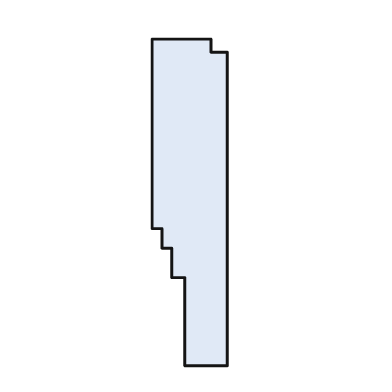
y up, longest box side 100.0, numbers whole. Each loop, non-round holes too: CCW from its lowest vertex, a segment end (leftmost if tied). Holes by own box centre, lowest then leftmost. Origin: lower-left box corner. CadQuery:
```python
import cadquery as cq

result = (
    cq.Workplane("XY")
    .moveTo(10.0, 0.0)
    .lineTo(23.0, 0.0)
    .lineTo(23.0, 96.0)
    .lineTo(18.0, 96.0)
    .lineTo(18.0, 100.0)
    .lineTo(0.0, 100.0)
    .lineTo(0.0, 42.0)
    .lineTo(3.0, 42.0)
    .lineTo(3.0, 36.0)
    .lineTo(6.0, 36.0)
    .lineTo(6.0, 27.0)
    .lineTo(10.0, 27.0)
    .close()
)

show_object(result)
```